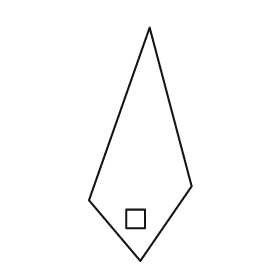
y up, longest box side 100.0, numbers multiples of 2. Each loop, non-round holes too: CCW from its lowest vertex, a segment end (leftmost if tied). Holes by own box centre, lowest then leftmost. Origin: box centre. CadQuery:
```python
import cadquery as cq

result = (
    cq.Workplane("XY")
    .moveTo(0.0, -50.0)
    .lineTo(22.0, -18.0)
    .lineTo(4.0, 50.0)
    .lineTo(-22.0, -24.0)
    .close()
    .moveTo(-6.0, -36.0)
    .lineTo(2.0, -36.0)
    .lineTo(2.0, -28.0)
    .lineTo(-6.0, -28.0)
    .close()
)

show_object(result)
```